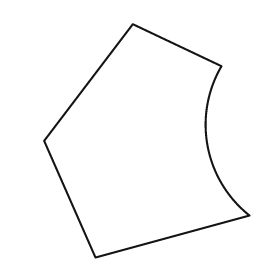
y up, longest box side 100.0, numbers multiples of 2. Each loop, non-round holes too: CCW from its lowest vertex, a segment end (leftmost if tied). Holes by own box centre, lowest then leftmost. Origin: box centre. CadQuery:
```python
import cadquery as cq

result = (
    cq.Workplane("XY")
    .moveTo(-22.0, -50.0)
    .lineTo(44.0, -32.0)
    .threePointArc((26.0, -2.0), (32.0, 32.0))
    .lineTo(-6.0, 50.0)
    .lineTo(-44.0, 0.0)
    .close()
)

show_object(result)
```